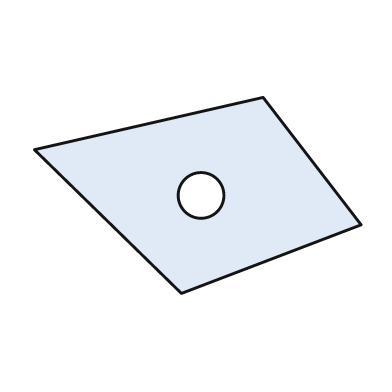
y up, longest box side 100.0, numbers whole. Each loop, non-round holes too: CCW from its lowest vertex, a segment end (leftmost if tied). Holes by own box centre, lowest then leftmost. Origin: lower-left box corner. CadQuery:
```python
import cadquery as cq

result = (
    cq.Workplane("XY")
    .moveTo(45.0, 0.0)
    .lineTo(100.0, 21.0)
    .lineTo(70.0, 60.0)
    .lineTo(0.0, 44.0)
    .close()
    .moveTo(51.0, 30.0)
    .circle(7.0)
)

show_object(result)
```